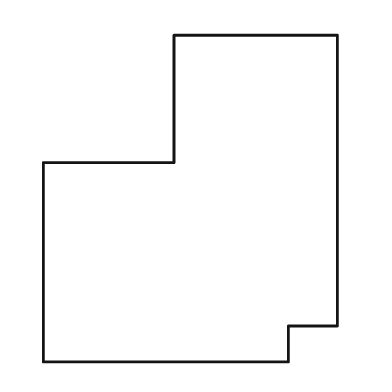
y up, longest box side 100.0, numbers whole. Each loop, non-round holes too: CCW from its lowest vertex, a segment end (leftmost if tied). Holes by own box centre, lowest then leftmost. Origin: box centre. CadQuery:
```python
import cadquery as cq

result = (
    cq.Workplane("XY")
    .moveTo(-45.0, -50.0)
    .lineTo(30.0, -50.0)
    .lineTo(30.0, -39.0)
    .lineTo(45.0, -39.0)
    .lineTo(45.0, 50.0)
    .lineTo(-5.0, 50.0)
    .lineTo(-5.0, 11.0)
    .lineTo(-45.0, 11.0)
    .close()
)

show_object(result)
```